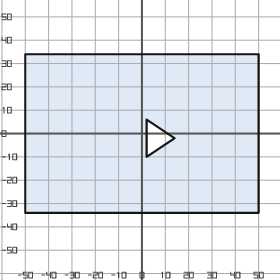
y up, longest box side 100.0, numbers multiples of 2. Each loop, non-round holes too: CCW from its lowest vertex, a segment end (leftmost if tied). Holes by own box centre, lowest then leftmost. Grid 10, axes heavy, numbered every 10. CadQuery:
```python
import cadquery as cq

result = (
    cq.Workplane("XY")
    .moveTo(-50.0, -34.0)
    .lineTo(50.0, -34.0)
    .lineTo(50.0, 34.0)
    .lineTo(-50.0, 34.0)
    .close()
    .moveTo(2.0, -10.0)
    .lineTo(14.0, -2.0)
    .lineTo(2.0, 6.0)
    .close()
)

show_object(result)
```